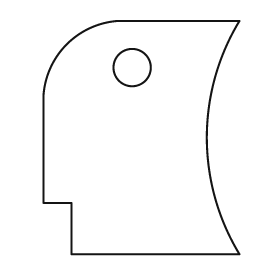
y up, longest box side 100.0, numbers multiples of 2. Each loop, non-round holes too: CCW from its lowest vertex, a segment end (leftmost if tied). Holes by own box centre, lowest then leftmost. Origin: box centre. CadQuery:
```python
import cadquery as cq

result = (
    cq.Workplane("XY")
    .moveTo(-30.0, -50.0)
    .lineTo(42.0, -50.0)
    .threePointArc((28.0, 0.0), (42.0, 50.0))
    .lineTo(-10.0, 50.0)
    .threePointArc((-32.0, 40.0), (-42.0, 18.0))
    .lineTo(-42.0, -28.0)
    .lineTo(-30.0, -28.0)
    .close()
    .moveTo(-4.0, 30.0)
    .circle(8.0)
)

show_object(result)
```